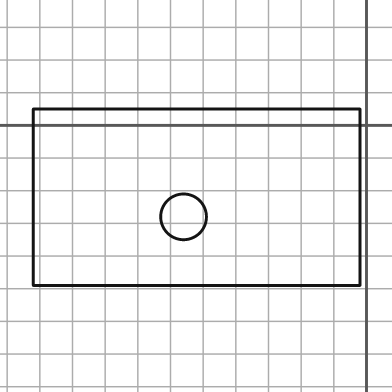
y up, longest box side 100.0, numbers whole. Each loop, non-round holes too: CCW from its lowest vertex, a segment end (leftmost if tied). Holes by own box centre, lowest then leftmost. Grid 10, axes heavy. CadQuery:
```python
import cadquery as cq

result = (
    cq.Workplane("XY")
    .moveTo(-102.0, -49.0)
    .lineTo(-2.0, -49.0)
    .lineTo(-2.0, 5.0)
    .lineTo(-102.0, 5.0)
    .close()
    .moveTo(-56.0, -28.0)
    .circle(7.0)
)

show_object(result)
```